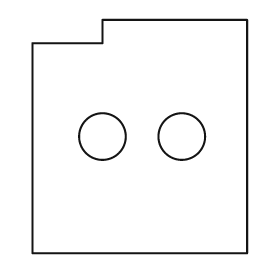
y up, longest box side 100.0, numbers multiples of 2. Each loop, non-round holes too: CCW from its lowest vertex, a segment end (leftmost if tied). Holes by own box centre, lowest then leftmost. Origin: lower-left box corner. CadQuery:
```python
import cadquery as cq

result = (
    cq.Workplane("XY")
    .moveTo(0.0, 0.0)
    .lineTo(92.0, 0.0)
    .lineTo(92.0, 100.0)
    .lineTo(30.0, 100.0)
    .lineTo(30.0, 90.0)
    .lineTo(0.0, 90.0)
    .close()
    .moveTo(30.0, 50.0)
    .circle(10.0)
    .moveTo(64.0, 50.0)
    .circle(10.0)
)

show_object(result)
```